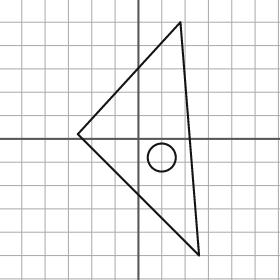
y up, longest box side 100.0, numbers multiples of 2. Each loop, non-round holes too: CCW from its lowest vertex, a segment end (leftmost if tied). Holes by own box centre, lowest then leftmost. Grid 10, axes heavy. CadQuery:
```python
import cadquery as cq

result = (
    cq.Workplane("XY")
    .moveTo(26.0, -50.0)
    .lineTo(18.0, 50.0)
    .lineTo(-26.0, 2.0)
    .close()
    .moveTo(10.0, -8.0)
    .circle(6.0)
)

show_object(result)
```